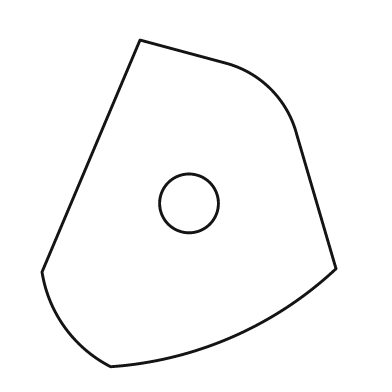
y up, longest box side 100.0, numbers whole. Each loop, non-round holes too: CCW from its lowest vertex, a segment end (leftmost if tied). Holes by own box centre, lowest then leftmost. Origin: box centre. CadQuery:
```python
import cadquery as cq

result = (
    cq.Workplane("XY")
    .moveTo(-24.0, -50.0)
    .threePointArc((13.0, -41.0), (45.0, -20.0))
    .lineTo(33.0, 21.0)
    .threePointArc((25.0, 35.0), (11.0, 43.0))
    .lineTo(-15.0, 50.0)
    .lineTo(-45.0, -21.0)
    .threePointArc((-38.0, -38.0), (-24.0, -50.0))
    .close()
    .moveTo(0.0, 0.0)
    .circle(9.0)
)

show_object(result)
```